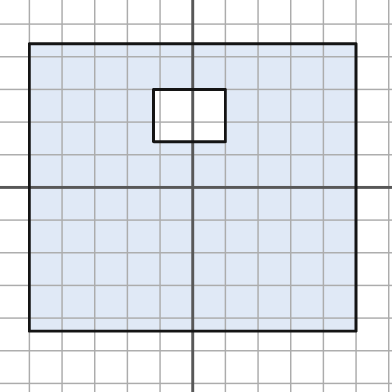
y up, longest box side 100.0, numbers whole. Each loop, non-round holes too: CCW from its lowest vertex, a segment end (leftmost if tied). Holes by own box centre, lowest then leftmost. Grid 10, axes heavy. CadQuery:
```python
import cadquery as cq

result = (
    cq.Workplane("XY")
    .moveTo(-50.0, -44.0)
    .lineTo(50.0, -44.0)
    .lineTo(50.0, 44.0)
    .lineTo(-50.0, 44.0)
    .close()
    .moveTo(-12.0, 14.0)
    .lineTo(10.0, 14.0)
    .lineTo(10.0, 30.0)
    .lineTo(-12.0, 30.0)
    .close()
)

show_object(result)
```